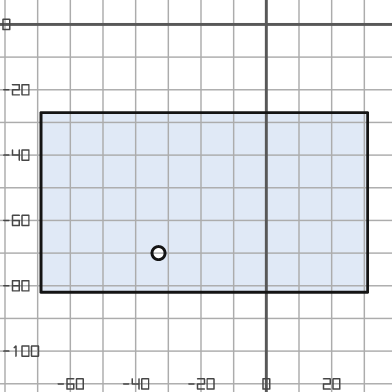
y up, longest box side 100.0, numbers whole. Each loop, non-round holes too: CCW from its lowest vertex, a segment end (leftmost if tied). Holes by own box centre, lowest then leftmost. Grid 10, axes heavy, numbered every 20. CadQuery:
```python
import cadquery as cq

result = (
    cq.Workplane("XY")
    .moveTo(-69.0, -82.0)
    .lineTo(31.0, -82.0)
    .lineTo(31.0, -27.0)
    .lineTo(-69.0, -27.0)
    .close()
    .moveTo(-33.0, -70.0)
    .circle(2.0)
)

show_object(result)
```